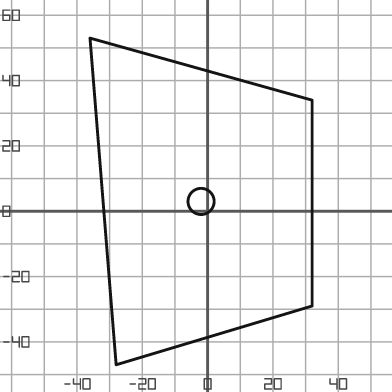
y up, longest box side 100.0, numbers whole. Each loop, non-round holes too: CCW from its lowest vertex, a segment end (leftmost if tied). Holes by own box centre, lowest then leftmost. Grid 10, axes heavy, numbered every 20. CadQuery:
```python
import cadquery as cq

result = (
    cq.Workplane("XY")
    .moveTo(-28.0, -47.0)
    .lineTo(32.0, -29.0)
    .lineTo(32.0, 34.0)
    .lineTo(-36.0, 53.0)
    .close()
    .moveTo(-2.0, 3.0)
    .circle(4.0)
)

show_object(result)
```